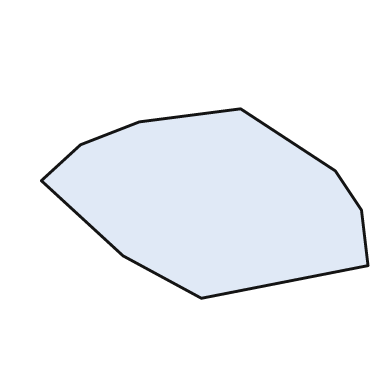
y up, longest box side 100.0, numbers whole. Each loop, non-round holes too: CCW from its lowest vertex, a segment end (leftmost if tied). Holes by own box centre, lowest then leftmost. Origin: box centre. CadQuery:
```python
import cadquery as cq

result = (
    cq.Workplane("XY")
    .moveTo(-1.0, -29.0)
    .lineTo(50.0, -19.0)
    .lineTo(48.0, -2.0)
    .lineTo(40.0, 10.0)
    .lineTo(11.0, 29.0)
    .lineTo(-20.0, 25.0)
    .lineTo(-38.0, 18.0)
    .lineTo(-50.0, 7.0)
    .lineTo(-25.0, -16.0)
    .close()
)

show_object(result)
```